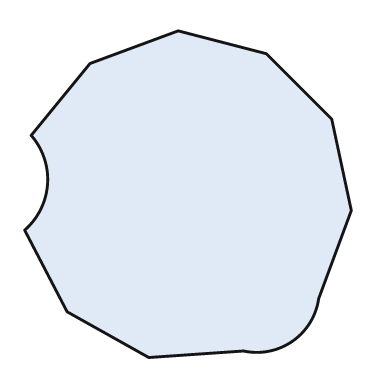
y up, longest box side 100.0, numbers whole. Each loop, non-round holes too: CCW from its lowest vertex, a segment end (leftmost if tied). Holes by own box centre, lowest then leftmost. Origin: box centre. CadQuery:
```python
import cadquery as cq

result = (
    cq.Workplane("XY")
    .moveTo(-12.0, -50.0)
    .lineTo(17.0, -48.0)
    .threePointArc((32.0, -45.0), (40.0, -32.0))
    .lineTo(50.0, -5.0)
    .lineTo(44.0, 23.0)
    .lineTo(24.0, 43.0)
    .lineTo(-3.0, 50.0)
    .lineTo(-30.0, 40.0)
    .lineTo(-48.0, 18.0)
    .threePointArc((-43.0, 3.0), (-50.0, -11.0))
    .lineTo(-37.0, -36.0)
    .close()
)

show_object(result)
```